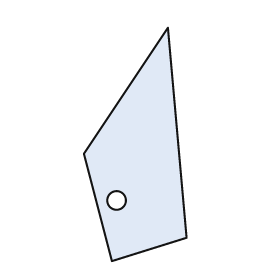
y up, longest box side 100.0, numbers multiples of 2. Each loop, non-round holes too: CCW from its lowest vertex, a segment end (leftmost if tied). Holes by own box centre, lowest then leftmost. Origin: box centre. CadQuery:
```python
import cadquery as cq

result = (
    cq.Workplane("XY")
    .moveTo(-10.0, -50.0)
    .lineTo(22.0, -40.0)
    .lineTo(14.0, 50.0)
    .lineTo(-22.0, -4.0)
    .close()
    .moveTo(-8.0, -24.0)
    .circle(4.0)
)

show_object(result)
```